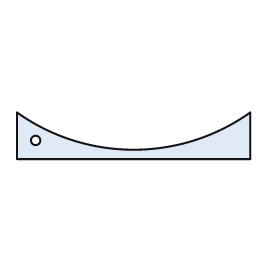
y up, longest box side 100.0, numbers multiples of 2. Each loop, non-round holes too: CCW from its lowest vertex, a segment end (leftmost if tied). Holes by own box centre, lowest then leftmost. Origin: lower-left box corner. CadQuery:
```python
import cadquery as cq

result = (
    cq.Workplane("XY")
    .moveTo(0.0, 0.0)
    .lineTo(100.0, 0.0)
    .lineTo(100.0, 20.0)
    .threePointArc((50.0, 4.0), (0.0, 20.0))
    .close()
    .moveTo(8.0, 8.0)
    .circle(2.0)
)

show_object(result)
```